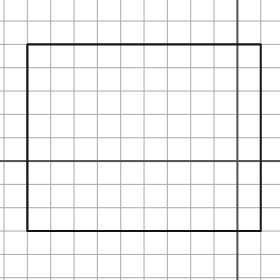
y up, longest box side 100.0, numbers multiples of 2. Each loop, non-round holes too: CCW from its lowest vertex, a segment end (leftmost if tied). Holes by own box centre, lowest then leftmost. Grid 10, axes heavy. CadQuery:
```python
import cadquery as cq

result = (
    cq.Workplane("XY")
    .moveTo(-90.0, -30.0)
    .lineTo(10.0, -30.0)
    .lineTo(10.0, 50.0)
    .lineTo(-90.0, 50.0)
    .close()
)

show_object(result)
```